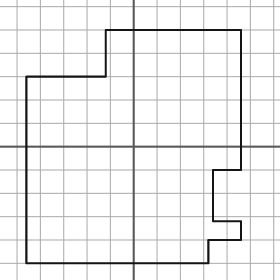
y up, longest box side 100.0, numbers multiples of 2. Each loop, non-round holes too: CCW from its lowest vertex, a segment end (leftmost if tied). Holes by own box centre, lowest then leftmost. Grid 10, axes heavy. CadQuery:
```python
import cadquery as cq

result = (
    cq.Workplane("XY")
    .moveTo(-46.0, -50.0)
    .lineTo(32.0, -50.0)
    .lineTo(32.0, -40.0)
    .lineTo(46.0, -40.0)
    .lineTo(46.0, -32.0)
    .lineTo(34.0, -32.0)
    .lineTo(34.0, -10.0)
    .lineTo(46.0, -10.0)
    .lineTo(46.0, 50.0)
    .lineTo(-12.0, 50.0)
    .lineTo(-12.0, 30.0)
    .lineTo(-46.0, 30.0)
    .close()
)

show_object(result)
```